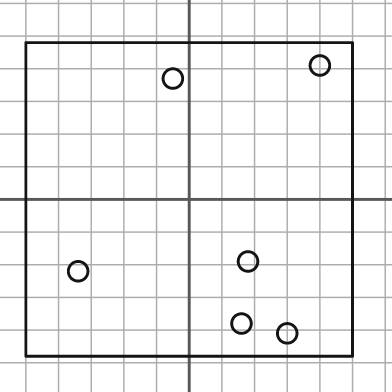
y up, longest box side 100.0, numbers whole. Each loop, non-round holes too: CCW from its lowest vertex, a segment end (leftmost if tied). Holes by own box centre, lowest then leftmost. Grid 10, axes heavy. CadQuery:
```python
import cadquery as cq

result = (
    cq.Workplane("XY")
    .moveTo(-50.0, -48.0)
    .lineTo(50.0, -48.0)
    .lineTo(50.0, 48.0)
    .lineTo(-50.0, 48.0)
    .close()
    .moveTo(30.0, -41.0)
    .circle(3.0)
    .moveTo(16.0, -38.0)
    .circle(3.0)
    .moveTo(-34.0, -22.0)
    .circle(3.0)
    .moveTo(18.0, -19.0)
    .circle(3.0)
    .moveTo(-5.0, 37.0)
    .circle(3.0)
    .moveTo(40.0, 41.0)
    .circle(3.0)
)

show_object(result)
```